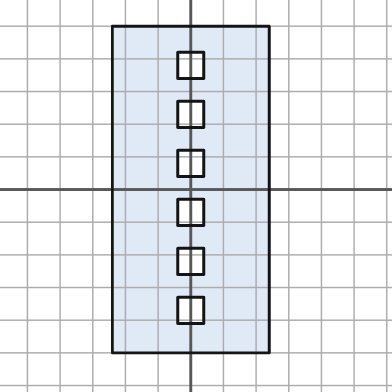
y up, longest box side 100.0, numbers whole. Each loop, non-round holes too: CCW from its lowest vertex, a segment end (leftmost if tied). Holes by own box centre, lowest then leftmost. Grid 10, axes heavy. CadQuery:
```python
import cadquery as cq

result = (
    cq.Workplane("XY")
    .moveTo(-24.0, -50.0)
    .lineTo(24.0, -50.0)
    .lineTo(24.0, 50.0)
    .lineTo(-24.0, 50.0)
    .close()
    .moveTo(-4.0, -41.0)
    .lineTo(4.0, -41.0)
    .lineTo(4.0, -33.0)
    .lineTo(-4.0, -33.0)
    .close()
    .moveTo(-4.0, -26.0)
    .lineTo(4.0, -26.0)
    .lineTo(4.0, -18.0)
    .lineTo(-4.0, -18.0)
    .close()
    .moveTo(-4.0, -11.0)
    .lineTo(4.0, -11.0)
    .lineTo(4.0, -3.0)
    .lineTo(-4.0, -3.0)
    .close()
    .moveTo(-4.0, 4.0)
    .lineTo(4.0, 4.0)
    .lineTo(4.0, 12.0)
    .lineTo(-4.0, 12.0)
    .close()
    .moveTo(-4.0, 19.0)
    .lineTo(4.0, 19.0)
    .lineTo(4.0, 27.0)
    .lineTo(-4.0, 27.0)
    .close()
    .moveTo(-4.0, 34.0)
    .lineTo(4.0, 34.0)
    .lineTo(4.0, 42.0)
    .lineTo(-4.0, 42.0)
    .close()
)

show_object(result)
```